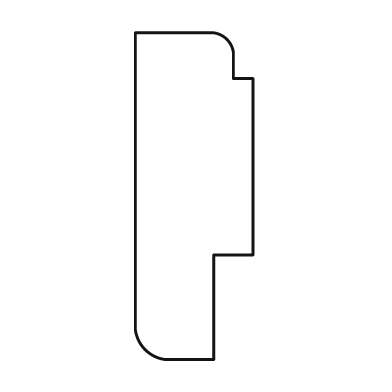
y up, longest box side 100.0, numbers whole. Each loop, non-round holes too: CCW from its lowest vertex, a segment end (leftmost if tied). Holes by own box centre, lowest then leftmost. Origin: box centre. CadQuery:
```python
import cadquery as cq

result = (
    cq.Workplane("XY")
    .moveTo(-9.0, -50.0)
    .lineTo(6.0, -50.0)
    .lineTo(6.0, -18.0)
    .lineTo(18.0, -18.0)
    .lineTo(18.0, 36.0)
    .lineTo(12.0, 36.0)
    .lineTo(12.0, 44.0)
    .threePointArc((10.0, 48.0), (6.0, 50.0))
    .lineTo(-18.0, 50.0)
    .lineTo(-18.0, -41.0)
    .threePointArc((-15.0, -47.0), (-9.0, -50.0))
    .close()
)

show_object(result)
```